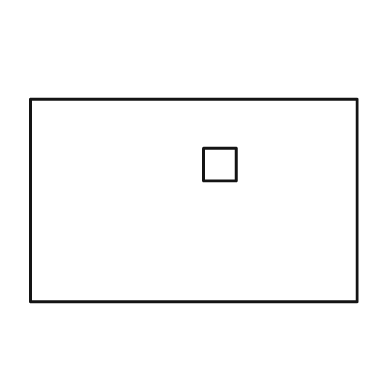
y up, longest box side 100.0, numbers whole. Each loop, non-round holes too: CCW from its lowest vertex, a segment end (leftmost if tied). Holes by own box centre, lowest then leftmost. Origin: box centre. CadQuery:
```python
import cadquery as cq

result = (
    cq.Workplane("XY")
    .moveTo(-50.0, -31.0)
    .lineTo(50.0, -31.0)
    .lineTo(50.0, 31.0)
    .lineTo(-50.0, 31.0)
    .close()
    .moveTo(3.0, 6.0)
    .lineTo(13.0, 6.0)
    .lineTo(13.0, 16.0)
    .lineTo(3.0, 16.0)
    .close()
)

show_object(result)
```